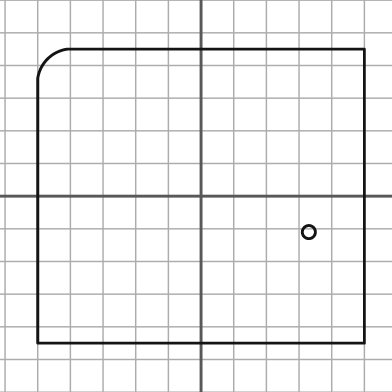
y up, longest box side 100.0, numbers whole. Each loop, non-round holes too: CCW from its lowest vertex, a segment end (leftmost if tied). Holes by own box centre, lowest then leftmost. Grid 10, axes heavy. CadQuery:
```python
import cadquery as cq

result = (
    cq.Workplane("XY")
    .moveTo(-50.0, -45.0)
    .lineTo(50.0, -45.0)
    .lineTo(50.0, 45.0)
    .lineTo(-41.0, 45.0)
    .threePointArc((-47.0, 42.0), (-50.0, 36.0))
    .close()
    .moveTo(33.0, -11.0)
    .circle(2.0)
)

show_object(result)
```